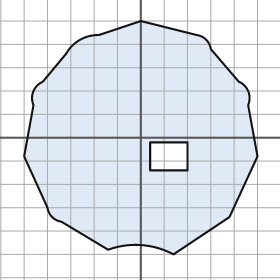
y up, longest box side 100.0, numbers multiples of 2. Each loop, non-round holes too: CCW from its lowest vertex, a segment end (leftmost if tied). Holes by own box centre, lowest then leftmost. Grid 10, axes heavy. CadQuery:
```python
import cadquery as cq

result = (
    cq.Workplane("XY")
    .moveTo(14.0, -50.0)
    .lineTo(38.0, -34.0)
    .lineTo(50.0, -8.0)
    .lineTo(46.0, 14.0)
    .threePointArc((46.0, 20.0), (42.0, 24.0))
    .lineTo(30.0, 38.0)
    .threePointArc((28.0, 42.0), (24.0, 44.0))
    .lineTo(0.0, 50.0)
    .lineTo(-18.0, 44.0)
    .threePointArc((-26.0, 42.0), (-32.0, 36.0))
    .lineTo(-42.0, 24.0)
    .threePointArc((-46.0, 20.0), (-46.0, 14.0))
    .lineTo(-50.0, -8.0)
    .lineTo(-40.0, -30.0)
    .threePointArc((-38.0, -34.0), (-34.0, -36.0))
    .lineTo(-14.0, -48.0)
    .threePointArc((0.0, -46.0), (14.0, -50.0))
    .close()
    .moveTo(4.0, -14.0)
    .lineTo(20.0, -14.0)
    .lineTo(20.0, -2.0)
    .lineTo(4.0, -2.0)
    .close()
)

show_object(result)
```